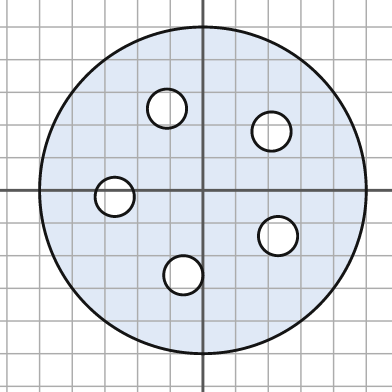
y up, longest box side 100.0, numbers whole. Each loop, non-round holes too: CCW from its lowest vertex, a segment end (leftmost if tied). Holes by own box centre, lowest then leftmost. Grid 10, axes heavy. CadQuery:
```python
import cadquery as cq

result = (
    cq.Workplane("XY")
    .moveTo(0.0, 0.0)
    .circle(50.0)
    .moveTo(-6.0, -26.0)
    .circle(6.0)
    .moveTo(23.0, -14.0)
    .circle(6.0)
    .moveTo(-27.0, -2.0)
    .circle(6.0)
    .moveTo(21.0, 18.0)
    .circle(6.0)
    .moveTo(-11.0, 25.0)
    .circle(6.0)
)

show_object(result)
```